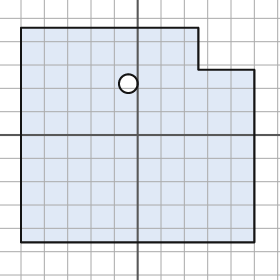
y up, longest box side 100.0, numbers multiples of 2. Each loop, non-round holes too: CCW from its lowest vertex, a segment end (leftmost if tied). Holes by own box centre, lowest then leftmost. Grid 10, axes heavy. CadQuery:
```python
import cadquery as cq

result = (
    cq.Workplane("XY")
    .moveTo(-50.0, -46.0)
    .lineTo(50.0, -46.0)
    .lineTo(50.0, 28.0)
    .lineTo(26.0, 28.0)
    .lineTo(26.0, 46.0)
    .lineTo(-50.0, 46.0)
    .close()
    .moveTo(-4.0, 22.0)
    .circle(4.0)
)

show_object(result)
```